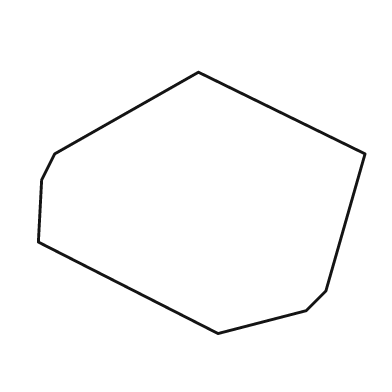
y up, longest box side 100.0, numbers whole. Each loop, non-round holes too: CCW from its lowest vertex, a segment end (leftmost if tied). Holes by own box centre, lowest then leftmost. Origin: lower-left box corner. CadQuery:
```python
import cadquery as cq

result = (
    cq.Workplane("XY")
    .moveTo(55.0, 0.0)
    .lineTo(82.0, 7.0)
    .lineTo(88.0, 13.0)
    .lineTo(100.0, 55.0)
    .lineTo(49.0, 80.0)
    .lineTo(5.0, 55.0)
    .lineTo(1.0, 47.0)
    .lineTo(0.0, 28.0)
    .close()
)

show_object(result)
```